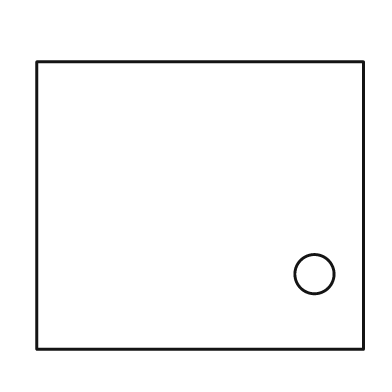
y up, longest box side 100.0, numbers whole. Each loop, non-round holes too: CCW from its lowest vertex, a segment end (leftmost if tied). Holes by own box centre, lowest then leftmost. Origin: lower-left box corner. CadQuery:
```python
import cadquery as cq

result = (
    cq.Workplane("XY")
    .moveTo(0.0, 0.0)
    .lineTo(100.0, 0.0)
    .lineTo(100.0, 88.0)
    .lineTo(0.0, 88.0)
    .close()
    .moveTo(85.0, 23.0)
    .circle(6.0)
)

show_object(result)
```